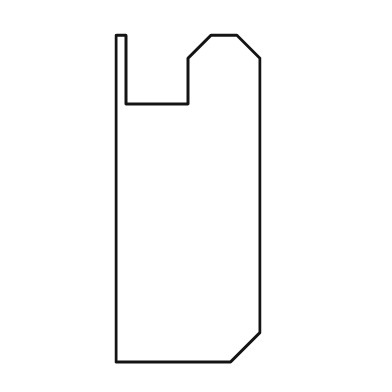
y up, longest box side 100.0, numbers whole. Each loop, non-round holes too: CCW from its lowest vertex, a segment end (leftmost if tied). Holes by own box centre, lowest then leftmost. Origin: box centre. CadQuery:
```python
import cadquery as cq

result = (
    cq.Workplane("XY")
    .moveTo(-22.0, -50.0)
    .lineTo(13.0, -50.0)
    .lineTo(22.0, -41.0)
    .lineTo(22.0, 43.0)
    .lineTo(15.0, 50.0)
    .lineTo(7.0, 50.0)
    .lineTo(0.0, 43.0)
    .lineTo(0.0, 29.0)
    .lineTo(-19.0, 29.0)
    .lineTo(-19.0, 50.0)
    .lineTo(-22.0, 50.0)
    .close()
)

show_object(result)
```